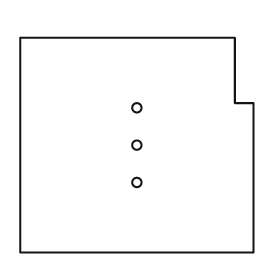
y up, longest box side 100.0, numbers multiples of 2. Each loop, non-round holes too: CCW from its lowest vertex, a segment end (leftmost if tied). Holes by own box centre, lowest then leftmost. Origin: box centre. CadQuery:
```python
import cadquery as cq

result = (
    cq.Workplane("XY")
    .moveTo(-50.0, -46.0)
    .lineTo(50.0, -46.0)
    .lineTo(50.0, 18.0)
    .lineTo(42.0, 18.0)
    .lineTo(42.0, 46.0)
    .lineTo(-50.0, 46.0)
    .close()
    .moveTo(0.0, -16.0)
    .circle(2.0)
    .moveTo(0.0, 0.0)
    .circle(2.0)
    .moveTo(0.0, 16.0)
    .circle(2.0)
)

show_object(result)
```